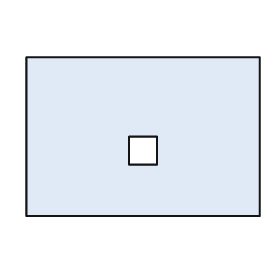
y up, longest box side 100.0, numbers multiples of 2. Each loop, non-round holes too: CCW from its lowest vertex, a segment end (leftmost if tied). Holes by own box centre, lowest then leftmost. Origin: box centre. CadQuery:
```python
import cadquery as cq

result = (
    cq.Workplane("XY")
    .moveTo(-50.0, -34.0)
    .lineTo(50.0, -34.0)
    .lineTo(50.0, 34.0)
    .lineTo(-50.0, 34.0)
    .close()
    .moveTo(-6.0, -12.0)
    .lineTo(6.0, -12.0)
    .lineTo(6.0, 0.0)
    .lineTo(-6.0, 0.0)
    .close()
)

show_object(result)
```